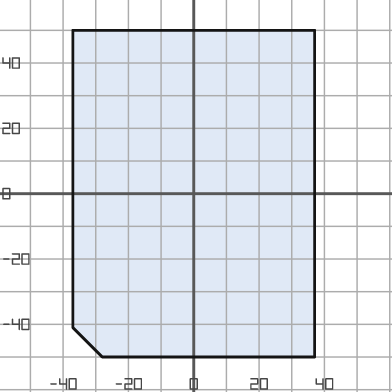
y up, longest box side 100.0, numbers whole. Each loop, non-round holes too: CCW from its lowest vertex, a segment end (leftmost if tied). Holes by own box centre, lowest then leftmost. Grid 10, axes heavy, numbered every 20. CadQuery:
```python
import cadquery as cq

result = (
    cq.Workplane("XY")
    .moveTo(-28.0, -50.0)
    .lineTo(37.0, -50.0)
    .lineTo(37.0, 50.0)
    .lineTo(-37.0, 50.0)
    .lineTo(-37.0, -41.0)
    .close()
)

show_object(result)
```